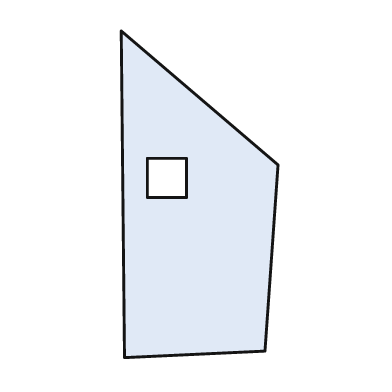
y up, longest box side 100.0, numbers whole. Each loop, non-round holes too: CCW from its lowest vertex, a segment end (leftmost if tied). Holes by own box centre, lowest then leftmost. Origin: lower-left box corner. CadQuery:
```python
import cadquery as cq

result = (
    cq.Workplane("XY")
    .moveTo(1.0, 0.0)
    .lineTo(44.0, 2.0)
    .lineTo(48.0, 59.0)
    .lineTo(0.0, 100.0)
    .close()
    .moveTo(8.0, 49.0)
    .lineTo(20.0, 49.0)
    .lineTo(20.0, 61.0)
    .lineTo(8.0, 61.0)
    .close()
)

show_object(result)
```